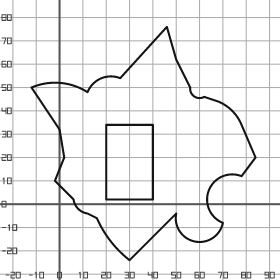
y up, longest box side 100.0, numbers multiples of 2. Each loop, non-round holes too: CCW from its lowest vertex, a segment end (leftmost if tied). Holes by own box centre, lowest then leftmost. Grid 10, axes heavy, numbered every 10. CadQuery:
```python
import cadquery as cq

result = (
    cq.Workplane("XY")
    .moveTo(30.0, -24.0)
    .lineTo(50.0, -4.0)
    .threePointArc((58.0, -16.0), (70.0, -8.0))
    .threePointArc((64.0, 6.0), (78.0, 12.0))
    .lineTo(84.0, 20.0)
    .lineTo(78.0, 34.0)
    .threePointArc((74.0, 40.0), (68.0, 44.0))
    .lineTo(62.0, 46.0)
    .threePointArc((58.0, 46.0), (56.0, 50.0))
    .lineTo(50.0, 62.0)
    .lineTo(46.0, 76.0)
    .lineTo(26.0, 54.0)
    .threePointArc((18.0, 54.0), (12.0, 48.0))
    .threePointArc((0.0, 52.0), (-12.0, 50.0))
    .lineTo(0.0, 32.0)
    .lineTo(2.0, 20.0)
    .lineTo(-2.0, 10.0)
    .lineTo(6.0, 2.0)
    .threePointArc((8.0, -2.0), (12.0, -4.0))
    .lineTo(16.0, -6.0)
    .threePointArc((22.0, -16.0), (30.0, -24.0))
    .close()
    .moveTo(20.0, 2.0)
    .lineTo(40.0, 2.0)
    .lineTo(40.0, 34.0)
    .lineTo(20.0, 34.0)
    .close()
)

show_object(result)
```